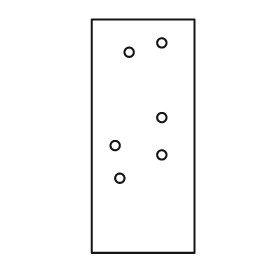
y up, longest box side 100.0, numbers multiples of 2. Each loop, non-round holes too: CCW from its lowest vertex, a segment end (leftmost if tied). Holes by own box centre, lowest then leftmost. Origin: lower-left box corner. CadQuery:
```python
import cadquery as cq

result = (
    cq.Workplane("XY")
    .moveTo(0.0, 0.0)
    .lineTo(44.0, 0.0)
    .lineTo(44.0, 100.0)
    .lineTo(0.0, 100.0)
    .close()
    .moveTo(12.0, 32.0)
    .circle(2.0)
    .moveTo(30.0, 42.0)
    .circle(2.0)
    .moveTo(10.0, 46.0)
    .circle(2.0)
    .moveTo(30.0, 58.0)
    .circle(2.0)
    .moveTo(16.0, 86.0)
    .circle(2.0)
    .moveTo(30.0, 90.0)
    .circle(2.0)
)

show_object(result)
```